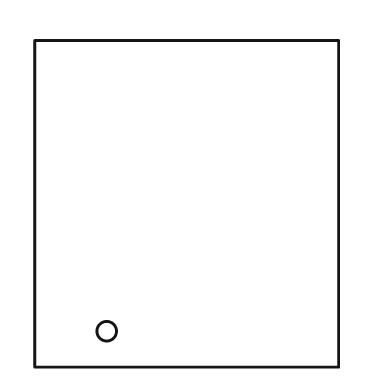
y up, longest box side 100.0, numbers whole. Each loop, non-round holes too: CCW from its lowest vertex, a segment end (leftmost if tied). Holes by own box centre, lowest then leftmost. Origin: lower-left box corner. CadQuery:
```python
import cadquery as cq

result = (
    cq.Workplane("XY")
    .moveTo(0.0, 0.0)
    .lineTo(93.0, 0.0)
    .lineTo(93.0, 100.0)
    .lineTo(0.0, 100.0)
    .close()
    .moveTo(22.0, 11.0)
    .circle(3.0)
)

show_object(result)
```